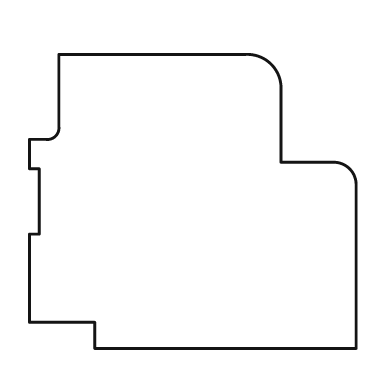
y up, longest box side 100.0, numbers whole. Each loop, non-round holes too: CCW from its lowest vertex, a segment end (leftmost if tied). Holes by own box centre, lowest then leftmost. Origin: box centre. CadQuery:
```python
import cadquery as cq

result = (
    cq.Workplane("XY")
    .moveTo(-30.0, -45.0)
    .lineTo(50.0, -45.0)
    .lineTo(50.0, 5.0)
    .threePointArc((48.0, 10.0), (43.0, 12.0))
    .lineTo(27.0, 12.0)
    .lineTo(27.0, 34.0)
    .threePointArc((24.0, 42.0), (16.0, 45.0))
    .lineTo(-41.0, 45.0)
    .lineTo(-41.0, 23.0)
    .threePointArc((-42.0, 20.0), (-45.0, 19.0))
    .lineTo(-50.0, 19.0)
    .lineTo(-50.0, 10.0)
    .lineTo(-47.0, 10.0)
    .lineTo(-47.0, -10.0)
    .lineTo(-50.0, -10.0)
    .lineTo(-50.0, -37.0)
    .lineTo(-30.0, -37.0)
    .close()
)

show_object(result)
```